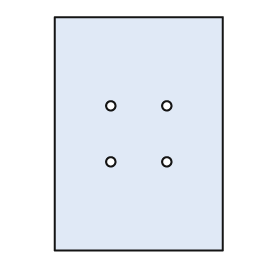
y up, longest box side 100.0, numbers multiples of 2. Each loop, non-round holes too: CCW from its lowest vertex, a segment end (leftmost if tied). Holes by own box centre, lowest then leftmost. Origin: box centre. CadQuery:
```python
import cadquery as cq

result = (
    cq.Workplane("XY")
    .moveTo(-36.0, -50.0)
    .lineTo(36.0, -50.0)
    .lineTo(36.0, 50.0)
    .lineTo(-36.0, 50.0)
    .close()
    .moveTo(-12.0, -12.0)
    .circle(2.0)
    .moveTo(12.0, -12.0)
    .circle(2.0)
    .moveTo(-12.0, 12.0)
    .circle(2.0)
    .moveTo(12.0, 12.0)
    .circle(2.0)
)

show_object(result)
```